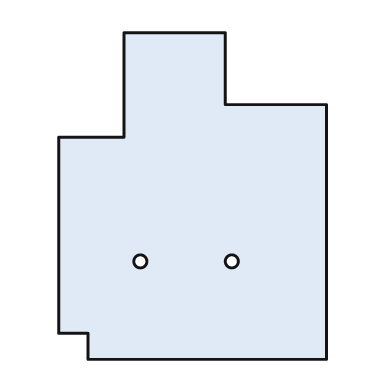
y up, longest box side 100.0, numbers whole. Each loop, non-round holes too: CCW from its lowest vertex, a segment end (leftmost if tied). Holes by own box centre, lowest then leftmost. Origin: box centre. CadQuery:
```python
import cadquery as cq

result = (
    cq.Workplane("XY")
    .moveTo(-32.0, -50.0)
    .lineTo(41.0, -50.0)
    .lineTo(41.0, 28.0)
    .lineTo(10.0, 28.0)
    .lineTo(10.0, 50.0)
    .lineTo(-21.0, 50.0)
    .lineTo(-21.0, 18.0)
    .lineTo(-41.0, 18.0)
    .lineTo(-41.0, -42.0)
    .lineTo(-32.0, -42.0)
    .close()
    .moveTo(-16.0, -20.0)
    .circle(2.0)
    .moveTo(12.0, -20.0)
    .circle(2.0)
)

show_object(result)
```